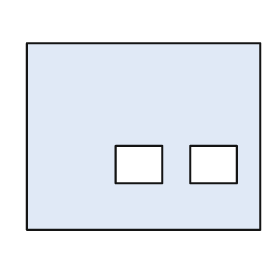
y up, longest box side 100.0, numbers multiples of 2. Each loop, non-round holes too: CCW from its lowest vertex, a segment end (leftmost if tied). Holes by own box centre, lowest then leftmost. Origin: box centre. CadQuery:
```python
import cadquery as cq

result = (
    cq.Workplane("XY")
    .moveTo(-50.0, -40.0)
    .lineTo(50.0, -40.0)
    .lineTo(50.0, 40.0)
    .lineTo(-50.0, 40.0)
    .close()
    .moveTo(-12.0, -20.0)
    .lineTo(8.0, -20.0)
    .lineTo(8.0, -4.0)
    .lineTo(-12.0, -4.0)
    .close()
    .moveTo(20.0, -20.0)
    .lineTo(40.0, -20.0)
    .lineTo(40.0, -4.0)
    .lineTo(20.0, -4.0)
    .close()
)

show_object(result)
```